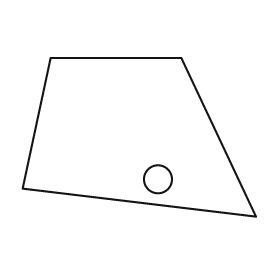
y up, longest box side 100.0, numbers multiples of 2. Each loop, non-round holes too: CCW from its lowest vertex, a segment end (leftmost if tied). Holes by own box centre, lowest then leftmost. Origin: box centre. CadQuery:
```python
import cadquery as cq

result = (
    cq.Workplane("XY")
    .moveTo(50.0, -34.0)
    .lineTo(18.0, 34.0)
    .lineTo(-38.0, 34.0)
    .lineTo(-50.0, -22.0)
    .close()
    .moveTo(8.0, -18.0)
    .circle(6.0)
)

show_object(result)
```